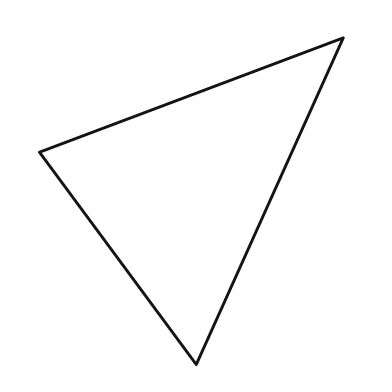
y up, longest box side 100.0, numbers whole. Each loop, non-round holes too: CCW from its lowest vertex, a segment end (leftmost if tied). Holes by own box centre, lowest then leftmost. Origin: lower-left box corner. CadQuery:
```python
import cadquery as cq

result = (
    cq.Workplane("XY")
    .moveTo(48.0, 0.0)
    .lineTo(93.0, 100.0)
    .lineTo(0.0, 65.0)
    .close()
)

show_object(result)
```